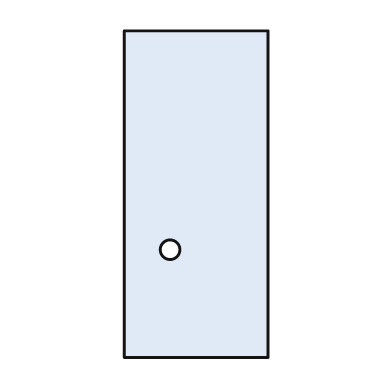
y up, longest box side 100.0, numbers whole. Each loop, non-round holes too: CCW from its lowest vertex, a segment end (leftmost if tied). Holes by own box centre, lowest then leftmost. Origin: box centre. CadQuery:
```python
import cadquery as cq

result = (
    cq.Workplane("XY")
    .moveTo(-22.0, -50.0)
    .lineTo(22.0, -50.0)
    .lineTo(22.0, 50.0)
    .lineTo(-22.0, 50.0)
    .close()
    .moveTo(-8.0, -17.0)
    .circle(3.0)
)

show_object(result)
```